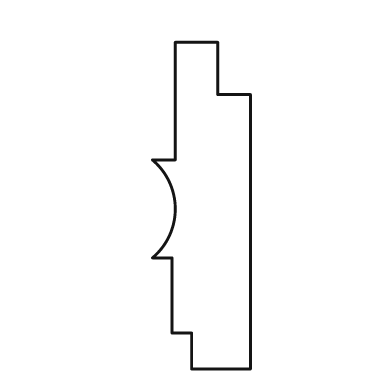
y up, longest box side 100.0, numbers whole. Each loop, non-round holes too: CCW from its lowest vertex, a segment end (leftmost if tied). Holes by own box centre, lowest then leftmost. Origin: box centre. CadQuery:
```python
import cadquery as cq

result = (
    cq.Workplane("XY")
    .moveTo(-3.0, -50.0)
    .lineTo(15.0, -50.0)
    .lineTo(15.0, 34.0)
    .lineTo(5.0, 34.0)
    .lineTo(5.0, 50.0)
    .lineTo(-8.0, 50.0)
    .lineTo(-8.0, 14.0)
    .lineTo(-15.0, 14.0)
    .threePointArc((-8.0, -1.0), (-15.0, -16.0))
    .lineTo(-9.0, -16.0)
    .lineTo(-9.0, -39.0)
    .lineTo(-3.0, -39.0)
    .close()
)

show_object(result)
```